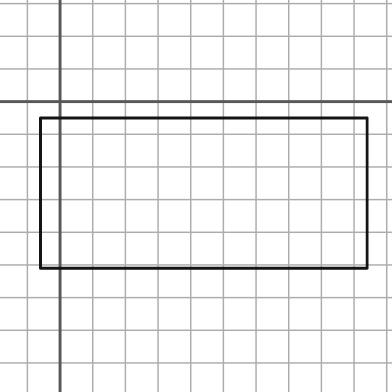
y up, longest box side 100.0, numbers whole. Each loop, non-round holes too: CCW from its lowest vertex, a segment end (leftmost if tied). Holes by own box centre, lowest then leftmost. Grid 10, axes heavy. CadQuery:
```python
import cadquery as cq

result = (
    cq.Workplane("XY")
    .moveTo(-6.0, -51.0)
    .lineTo(94.0, -51.0)
    .lineTo(94.0, -5.0)
    .lineTo(-6.0, -5.0)
    .close()
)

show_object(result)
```